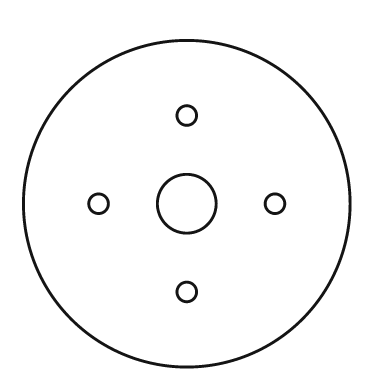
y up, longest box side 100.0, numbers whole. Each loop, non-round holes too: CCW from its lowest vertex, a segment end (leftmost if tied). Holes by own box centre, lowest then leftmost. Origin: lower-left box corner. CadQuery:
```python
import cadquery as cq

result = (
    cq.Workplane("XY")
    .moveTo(50.0, 50.0)
    .circle(50.0)
    .moveTo(50.0, 23.0)
    .circle(3.0)
    .moveTo(23.0, 50.0)
    .circle(3.0)
    .moveTo(50.0, 50.0)
    .circle(9.0)
    .moveTo(77.0, 50.0)
    .circle(3.0)
    .moveTo(50.0, 77.0)
    .circle(3.0)
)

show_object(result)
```